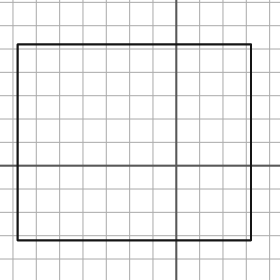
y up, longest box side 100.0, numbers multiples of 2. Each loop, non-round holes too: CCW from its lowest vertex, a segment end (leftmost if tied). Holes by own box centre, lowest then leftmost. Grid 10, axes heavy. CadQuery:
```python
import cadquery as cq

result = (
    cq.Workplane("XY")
    .moveTo(-68.0, -32.0)
    .lineTo(32.0, -32.0)
    .lineTo(32.0, 52.0)
    .lineTo(-68.0, 52.0)
    .close()
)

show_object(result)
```